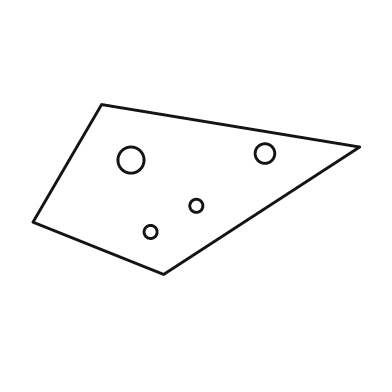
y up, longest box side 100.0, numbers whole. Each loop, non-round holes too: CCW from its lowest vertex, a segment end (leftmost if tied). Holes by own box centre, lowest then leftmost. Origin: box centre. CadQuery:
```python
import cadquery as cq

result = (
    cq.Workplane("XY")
    .moveTo(-10.0, -26.0)
    .lineTo(50.0, 13.0)
    .lineTo(-29.0, 26.0)
    .lineTo(-50.0, -10.0)
    .close()
    .moveTo(-14.0, -13.0)
    .circle(2.0)
    .moveTo(0.0, -5.0)
    .circle(2.0)
    .moveTo(-20.0, 9.0)
    .circle(4.0)
    .moveTo(21.0, 11.0)
    .circle(3.0)
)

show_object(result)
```